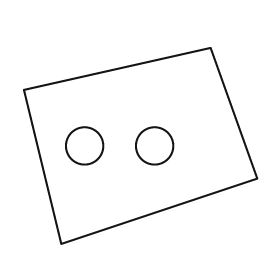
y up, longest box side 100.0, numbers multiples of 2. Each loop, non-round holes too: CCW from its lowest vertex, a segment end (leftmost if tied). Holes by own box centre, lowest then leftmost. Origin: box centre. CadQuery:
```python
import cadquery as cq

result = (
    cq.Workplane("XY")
    .moveTo(-34.0, -42.0)
    .lineTo(50.0, -14.0)
    .lineTo(30.0, 42.0)
    .lineTo(-50.0, 24.0)
    .close()
    .moveTo(-24.0, 0.0)
    .circle(8.0)
    .moveTo(6.0, 0.0)
    .circle(8.0)
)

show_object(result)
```